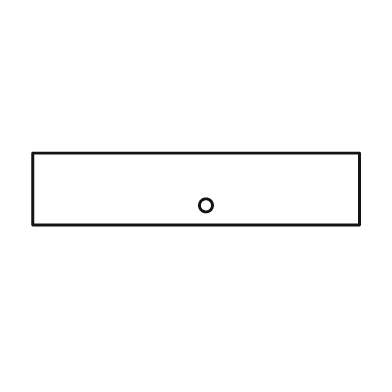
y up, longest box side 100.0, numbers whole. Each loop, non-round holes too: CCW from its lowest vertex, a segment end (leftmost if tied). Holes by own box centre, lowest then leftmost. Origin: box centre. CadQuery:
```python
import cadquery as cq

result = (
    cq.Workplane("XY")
    .moveTo(-50.0, -11.0)
    .lineTo(50.0, -11.0)
    .lineTo(50.0, 11.0)
    .lineTo(-50.0, 11.0)
    .close()
    .moveTo(3.0, -5.0)
    .circle(2.0)
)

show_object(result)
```